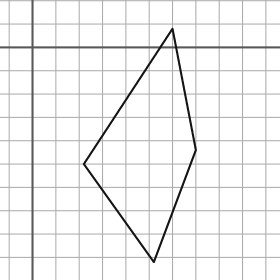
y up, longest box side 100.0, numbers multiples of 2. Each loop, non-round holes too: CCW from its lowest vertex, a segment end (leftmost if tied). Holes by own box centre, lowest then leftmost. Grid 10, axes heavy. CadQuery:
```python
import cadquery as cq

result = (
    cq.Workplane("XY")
    .moveTo(52.0, -92.0)
    .lineTo(70.0, -44.0)
    .lineTo(60.0, 8.0)
    .lineTo(22.0, -50.0)
    .close()
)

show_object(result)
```